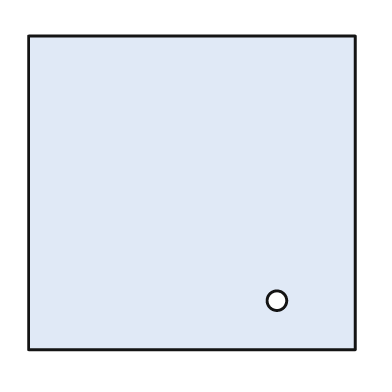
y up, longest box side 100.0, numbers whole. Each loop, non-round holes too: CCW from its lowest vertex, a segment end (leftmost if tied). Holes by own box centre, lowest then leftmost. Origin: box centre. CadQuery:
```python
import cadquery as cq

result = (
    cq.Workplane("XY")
    .moveTo(-50.0, -48.0)
    .lineTo(50.0, -48.0)
    .lineTo(50.0, 48.0)
    .lineTo(-50.0, 48.0)
    .close()
    .moveTo(26.0, -33.0)
    .circle(3.0)
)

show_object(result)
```